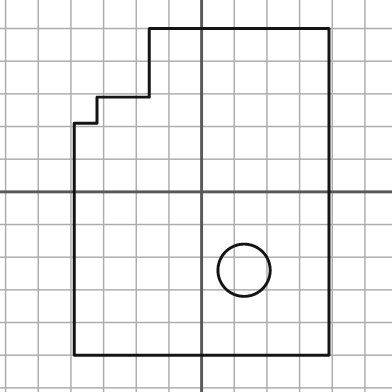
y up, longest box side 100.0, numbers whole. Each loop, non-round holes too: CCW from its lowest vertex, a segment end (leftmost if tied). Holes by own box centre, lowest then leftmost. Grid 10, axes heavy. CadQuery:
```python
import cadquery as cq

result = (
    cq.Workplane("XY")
    .moveTo(-39.0, -50.0)
    .lineTo(39.0, -50.0)
    .lineTo(39.0, 50.0)
    .lineTo(-16.0, 50.0)
    .lineTo(-16.0, 29.0)
    .lineTo(-32.0, 29.0)
    .lineTo(-32.0, 21.0)
    .lineTo(-39.0, 21.0)
    .close()
    .moveTo(13.0, -24.0)
    .circle(8.0)
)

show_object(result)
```